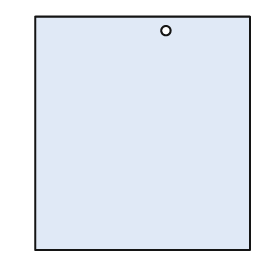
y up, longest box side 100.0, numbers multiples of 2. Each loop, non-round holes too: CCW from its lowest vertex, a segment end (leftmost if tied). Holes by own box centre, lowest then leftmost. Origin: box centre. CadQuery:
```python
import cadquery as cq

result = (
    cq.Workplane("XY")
    .moveTo(-46.0, -50.0)
    .lineTo(46.0, -50.0)
    .lineTo(46.0, 50.0)
    .lineTo(-46.0, 50.0)
    .close()
    .moveTo(10.0, 44.0)
    .circle(2.0)
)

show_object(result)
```